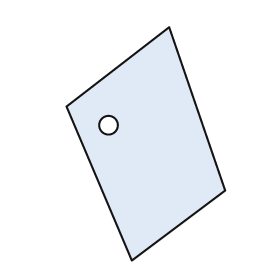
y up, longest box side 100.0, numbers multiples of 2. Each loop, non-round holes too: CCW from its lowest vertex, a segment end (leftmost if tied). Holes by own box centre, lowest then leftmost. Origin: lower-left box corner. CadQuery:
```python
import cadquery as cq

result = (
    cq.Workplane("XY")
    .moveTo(28.0, 0.0)
    .lineTo(68.0, 30.0)
    .lineTo(44.0, 100.0)
    .lineTo(0.0, 66.0)
    .close()
    .moveTo(18.0, 58.0)
    .circle(4.0)
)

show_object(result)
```